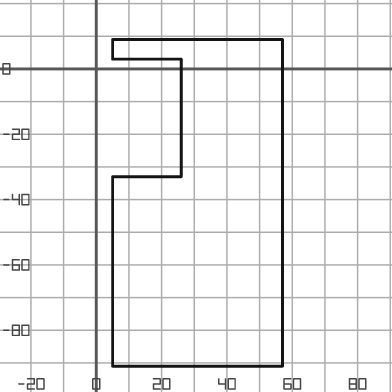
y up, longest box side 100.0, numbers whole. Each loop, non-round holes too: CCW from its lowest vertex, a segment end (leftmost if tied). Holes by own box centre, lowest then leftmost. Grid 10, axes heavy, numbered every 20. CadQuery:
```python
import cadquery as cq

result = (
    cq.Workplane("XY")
    .moveTo(5.0, -91.0)
    .lineTo(57.0, -91.0)
    .lineTo(57.0, 9.0)
    .lineTo(5.0, 9.0)
    .lineTo(5.0, 3.0)
    .lineTo(26.0, 3.0)
    .lineTo(26.0, -33.0)
    .lineTo(5.0, -33.0)
    .close()
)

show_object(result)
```